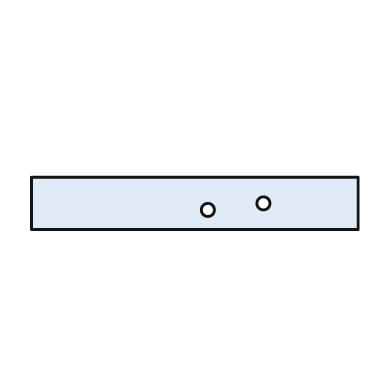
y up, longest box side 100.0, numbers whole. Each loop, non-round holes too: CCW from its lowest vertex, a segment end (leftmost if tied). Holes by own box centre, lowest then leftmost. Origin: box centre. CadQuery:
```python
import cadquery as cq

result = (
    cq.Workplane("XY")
    .moveTo(-50.0, -8.0)
    .lineTo(50.0, -8.0)
    .lineTo(50.0, 8.0)
    .lineTo(-50.0, 8.0)
    .close()
    .moveTo(4.0, -2.0)
    .circle(2.0)
    .moveTo(21.0, 0.0)
    .circle(2.0)
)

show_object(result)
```